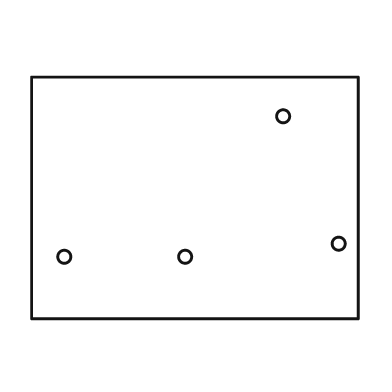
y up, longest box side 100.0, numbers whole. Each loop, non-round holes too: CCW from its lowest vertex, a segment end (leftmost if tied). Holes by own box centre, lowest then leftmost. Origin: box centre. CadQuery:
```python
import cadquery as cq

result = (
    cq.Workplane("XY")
    .moveTo(-50.0, -37.0)
    .lineTo(50.0, -37.0)
    .lineTo(50.0, 37.0)
    .lineTo(-50.0, 37.0)
    .close()
    .moveTo(-40.0, -18.0)
    .circle(2.0)
    .moveTo(-3.0, -18.0)
    .circle(2.0)
    .moveTo(44.0, -14.0)
    .circle(2.0)
    .moveTo(27.0, 25.0)
    .circle(2.0)
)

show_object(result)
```